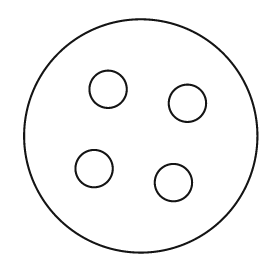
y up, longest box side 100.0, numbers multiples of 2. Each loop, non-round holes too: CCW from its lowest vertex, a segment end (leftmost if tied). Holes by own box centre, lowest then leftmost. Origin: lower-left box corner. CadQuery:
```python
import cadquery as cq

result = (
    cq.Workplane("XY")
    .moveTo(50.0, 50.0)
    .circle(50.0)
    .moveTo(64.0, 30.0)
    .circle(8.0)
    .moveTo(30.0, 36.0)
    .circle(8.0)
    .moveTo(70.0, 64.0)
    .circle(8.0)
    .moveTo(36.0, 70.0)
    .circle(8.0)
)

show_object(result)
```